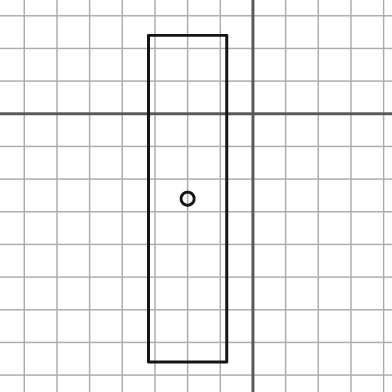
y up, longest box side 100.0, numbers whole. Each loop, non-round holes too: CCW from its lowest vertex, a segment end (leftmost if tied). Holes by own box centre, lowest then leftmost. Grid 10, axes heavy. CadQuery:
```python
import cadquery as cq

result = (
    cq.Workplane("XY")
    .moveTo(-32.0, -76.0)
    .lineTo(-8.0, -76.0)
    .lineTo(-8.0, 24.0)
    .lineTo(-32.0, 24.0)
    .close()
    .moveTo(-20.0, -26.0)
    .circle(2.0)
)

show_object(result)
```